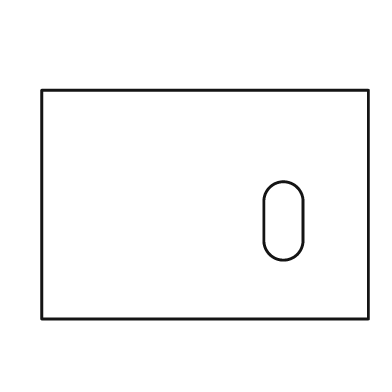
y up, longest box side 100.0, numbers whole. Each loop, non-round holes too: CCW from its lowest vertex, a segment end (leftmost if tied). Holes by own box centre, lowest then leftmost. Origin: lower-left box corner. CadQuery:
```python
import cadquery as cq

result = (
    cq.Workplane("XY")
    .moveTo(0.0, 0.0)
    .lineTo(100.0, 0.0)
    .lineTo(100.0, 70.0)
    .lineTo(0.0, 70.0)
    .close()
    .moveTo(68.0, 24.0)
    .threePointArc((74.0, 18.0), (80.0, 24.0))
    .lineTo(80.0, 36.0)
    .threePointArc((74.0, 42.0), (68.0, 36.0))
    .close()
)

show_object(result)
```